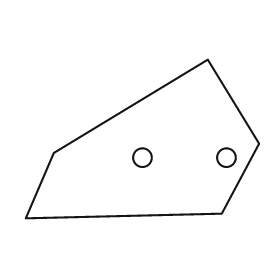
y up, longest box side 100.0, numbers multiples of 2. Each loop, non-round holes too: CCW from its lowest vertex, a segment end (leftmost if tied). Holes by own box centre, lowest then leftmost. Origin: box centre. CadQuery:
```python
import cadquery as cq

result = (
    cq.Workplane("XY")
    .moveTo(-50.0, -34.0)
    .lineTo(34.0, -32.0)
    .lineTo(50.0, -2.0)
    .lineTo(28.0, 34.0)
    .lineTo(-38.0, -6.0)
    .close()
    .moveTo(0.0, -8.0)
    .circle(4.0)
    .moveTo(36.0, -8.0)
    .circle(4.0)
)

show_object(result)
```